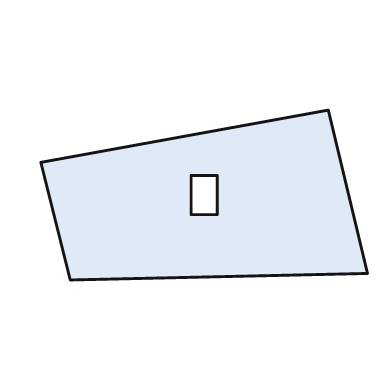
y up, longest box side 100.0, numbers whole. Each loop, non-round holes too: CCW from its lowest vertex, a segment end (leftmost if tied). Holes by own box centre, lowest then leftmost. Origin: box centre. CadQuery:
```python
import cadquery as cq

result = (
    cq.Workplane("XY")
    .moveTo(-41.0, -26.0)
    .lineTo(50.0, -24.0)
    .lineTo(38.0, 26.0)
    .lineTo(-50.0, 10.0)
    .close()
    .moveTo(-4.0, -6.0)
    .lineTo(4.0, -6.0)
    .lineTo(4.0, 6.0)
    .lineTo(-4.0, 6.0)
    .close()
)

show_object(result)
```